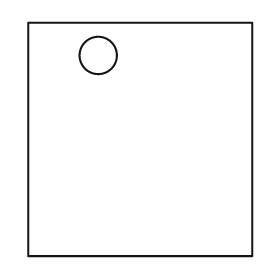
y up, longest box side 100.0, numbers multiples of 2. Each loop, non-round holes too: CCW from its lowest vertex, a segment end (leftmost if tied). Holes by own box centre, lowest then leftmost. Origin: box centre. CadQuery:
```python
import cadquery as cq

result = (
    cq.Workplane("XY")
    .moveTo(-48.0, -50.0)
    .lineTo(48.0, -50.0)
    .lineTo(48.0, 50.0)
    .lineTo(-48.0, 50.0)
    .close()
    .moveTo(-18.0, 36.0)
    .circle(8.0)
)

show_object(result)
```